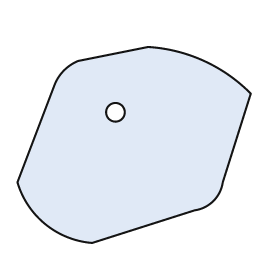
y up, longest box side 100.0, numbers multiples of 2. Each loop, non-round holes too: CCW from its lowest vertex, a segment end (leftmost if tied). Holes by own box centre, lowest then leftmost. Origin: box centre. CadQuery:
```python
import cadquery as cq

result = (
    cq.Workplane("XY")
    .moveTo(-18.0, -42.0)
    .lineTo(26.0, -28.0)
    .threePointArc((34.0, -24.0), (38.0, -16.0))
    .lineTo(50.0, 22.0)
    .threePointArc((30.0, 36.0), (6.0, 42.0))
    .lineTo(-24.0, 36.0)
    .threePointArc((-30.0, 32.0), (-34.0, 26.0))
    .lineTo(-50.0, -16.0)
    .threePointArc((-38.0, -34.0), (-18.0, -42.0))
    .close()
    .moveTo(-8.0, 14.0)
    .circle(4.0)
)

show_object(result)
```